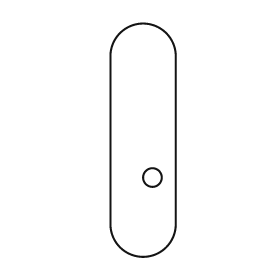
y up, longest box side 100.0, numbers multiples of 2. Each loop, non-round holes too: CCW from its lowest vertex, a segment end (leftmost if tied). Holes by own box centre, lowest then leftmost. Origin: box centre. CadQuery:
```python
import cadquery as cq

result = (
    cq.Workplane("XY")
    .moveTo(-14.0, -36.0)
    .threePointArc((0.0, -50.0), (14.0, -36.0))
    .lineTo(14.0, 36.0)
    .threePointArc((0.0, 50.0), (-14.0, 36.0))
    .close()
    .moveTo(4.0, -16.0)
    .circle(4.0)
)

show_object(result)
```